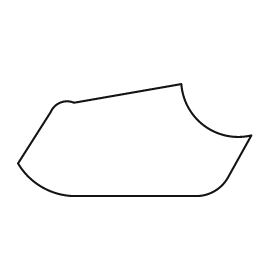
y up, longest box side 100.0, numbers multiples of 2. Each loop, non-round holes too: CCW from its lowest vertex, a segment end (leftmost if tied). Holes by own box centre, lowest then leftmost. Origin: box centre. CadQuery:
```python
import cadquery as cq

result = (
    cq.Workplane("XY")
    .moveTo(-26.0, -24.0)
    .lineTo(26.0, -24.0)
    .threePointArc((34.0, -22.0), (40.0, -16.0))
    .lineTo(50.0, 2.0)
    .threePointArc((30.0, 6.0), (20.0, 24.0))
    .lineTo(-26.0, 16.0)
    .threePointArc((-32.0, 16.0), (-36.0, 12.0))
    .lineTo(-50.0, -10.0)
    .threePointArc((-40.0, -20.0), (-26.0, -24.0))
    .close()
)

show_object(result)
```